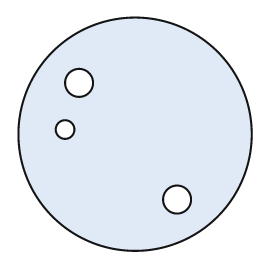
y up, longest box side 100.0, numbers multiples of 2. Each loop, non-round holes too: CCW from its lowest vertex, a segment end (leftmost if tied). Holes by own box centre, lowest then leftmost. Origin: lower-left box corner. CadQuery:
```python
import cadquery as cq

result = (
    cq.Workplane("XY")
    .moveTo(50.0, 50.0)
    .circle(50.0)
    .moveTo(68.0, 22.0)
    .circle(6.0)
    .moveTo(20.0, 52.0)
    .circle(4.0)
    .moveTo(26.0, 72.0)
    .circle(6.0)
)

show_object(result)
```